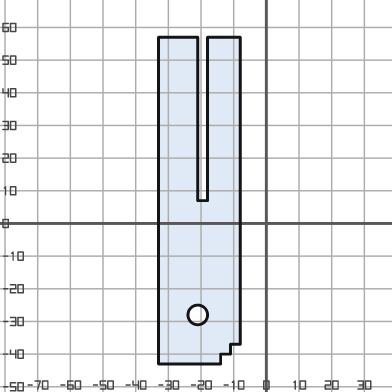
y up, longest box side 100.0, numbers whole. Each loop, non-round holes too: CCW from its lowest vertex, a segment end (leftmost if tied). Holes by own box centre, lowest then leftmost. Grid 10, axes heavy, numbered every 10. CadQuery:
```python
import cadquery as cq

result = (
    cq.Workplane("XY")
    .moveTo(-33.0, -43.0)
    .lineTo(-14.0, -43.0)
    .lineTo(-14.0, -40.0)
    .lineTo(-11.0, -40.0)
    .lineTo(-11.0, -37.0)
    .lineTo(-8.0, -37.0)
    .lineTo(-8.0, 57.0)
    .lineTo(-18.0, 57.0)
    .lineTo(-18.0, 7.0)
    .lineTo(-21.0, 7.0)
    .lineTo(-21.0, 57.0)
    .lineTo(-33.0, 57.0)
    .close()
    .moveTo(-21.0, -28.0)
    .circle(3.0)
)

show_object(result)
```